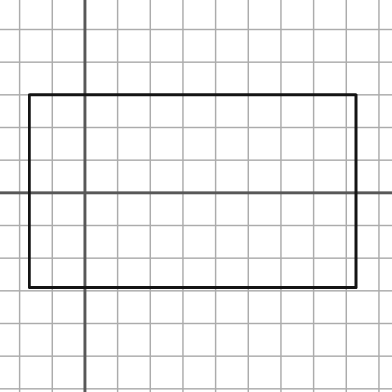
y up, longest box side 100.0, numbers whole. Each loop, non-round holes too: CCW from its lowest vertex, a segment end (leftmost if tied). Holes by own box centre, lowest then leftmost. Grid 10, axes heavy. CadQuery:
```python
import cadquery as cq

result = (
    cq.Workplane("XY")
    .moveTo(-17.0, -29.0)
    .lineTo(83.0, -29.0)
    .lineTo(83.0, 30.0)
    .lineTo(-17.0, 30.0)
    .close()
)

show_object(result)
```